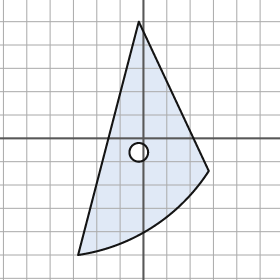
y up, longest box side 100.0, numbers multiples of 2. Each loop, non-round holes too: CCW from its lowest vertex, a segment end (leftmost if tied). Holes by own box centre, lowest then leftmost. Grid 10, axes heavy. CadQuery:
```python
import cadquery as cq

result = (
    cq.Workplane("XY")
    .moveTo(-28.0, -50.0)
    .threePointArc((4.0, -38.0), (28.0, -14.0))
    .lineTo(-2.0, 50.0)
    .close()
    .moveTo(-2.0, -6.0)
    .circle(4.0)
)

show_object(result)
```